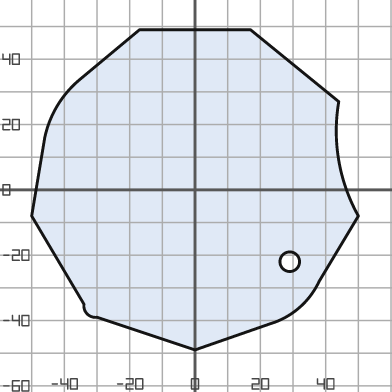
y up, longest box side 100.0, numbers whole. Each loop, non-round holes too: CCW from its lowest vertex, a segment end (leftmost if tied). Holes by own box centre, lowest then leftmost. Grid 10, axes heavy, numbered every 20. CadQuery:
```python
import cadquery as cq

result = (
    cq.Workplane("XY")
    .moveTo(0.0, -49.0)
    .lineTo(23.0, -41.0)
    .threePointArc((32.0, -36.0), (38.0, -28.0))
    .lineTo(50.0, -8.0)
    .threePointArc((44.0, 9.0), (44.0, 27.0))
    .lineTo(17.0, 49.0)
    .lineTo(-17.0, 49.0)
    .lineTo(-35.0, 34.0)
    .threePointArc((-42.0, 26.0), (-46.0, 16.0))
    .lineTo(-50.0, -8.0)
    .lineTo(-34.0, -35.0)
    .threePointArc((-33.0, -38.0), (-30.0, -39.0))
    .close()
    .moveTo(29.0, -22.0)
    .circle(3.0)
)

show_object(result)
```